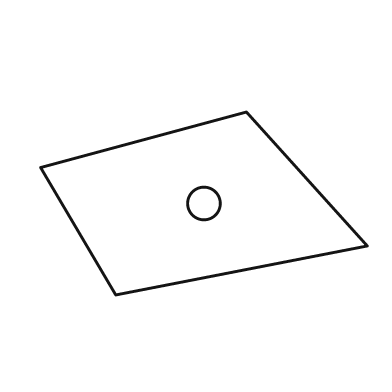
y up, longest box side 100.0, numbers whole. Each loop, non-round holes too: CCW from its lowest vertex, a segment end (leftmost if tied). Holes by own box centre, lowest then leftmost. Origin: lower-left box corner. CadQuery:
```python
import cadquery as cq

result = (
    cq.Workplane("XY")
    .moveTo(23.0, 0.0)
    .lineTo(100.0, 15.0)
    .lineTo(63.0, 56.0)
    .lineTo(0.0, 39.0)
    .close()
    .moveTo(50.0, 28.0)
    .circle(5.0)
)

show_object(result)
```